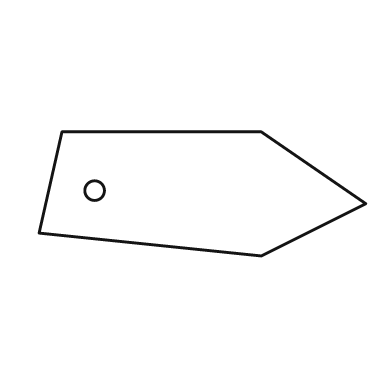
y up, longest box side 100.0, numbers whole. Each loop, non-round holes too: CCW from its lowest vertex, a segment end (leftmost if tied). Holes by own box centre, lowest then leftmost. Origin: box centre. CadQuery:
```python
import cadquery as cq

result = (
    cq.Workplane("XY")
    .moveTo(18.0, -19.0)
    .lineTo(50.0, -3.0)
    .lineTo(18.0, 19.0)
    .lineTo(-43.0, 19.0)
    .lineTo(-50.0, -12.0)
    .close()
    .moveTo(-33.0, 1.0)
    .circle(3.0)
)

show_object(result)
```